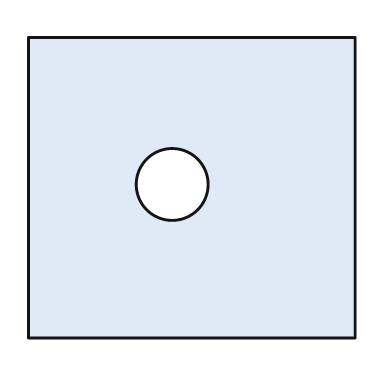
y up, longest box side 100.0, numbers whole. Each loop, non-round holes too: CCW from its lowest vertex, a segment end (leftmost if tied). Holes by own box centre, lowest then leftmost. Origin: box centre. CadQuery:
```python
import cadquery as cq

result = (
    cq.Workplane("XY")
    .moveTo(-50.0, -46.0)
    .lineTo(50.0, -46.0)
    .lineTo(50.0, 46.0)
    .lineTo(-50.0, 46.0)
    .close()
    .moveTo(-6.0, 1.0)
    .circle(11.0)
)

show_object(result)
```